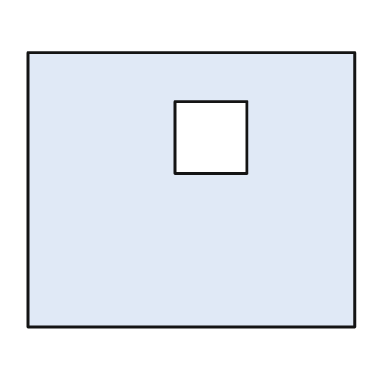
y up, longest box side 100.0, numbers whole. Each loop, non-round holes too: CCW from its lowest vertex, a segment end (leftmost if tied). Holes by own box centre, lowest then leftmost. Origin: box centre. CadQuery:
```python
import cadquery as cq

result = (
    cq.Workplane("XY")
    .moveTo(-50.0, -42.0)
    .lineTo(50.0, -42.0)
    .lineTo(50.0, 42.0)
    .lineTo(-50.0, 42.0)
    .close()
    .moveTo(-5.0, 5.0)
    .lineTo(17.0, 5.0)
    .lineTo(17.0, 27.0)
    .lineTo(-5.0, 27.0)
    .close()
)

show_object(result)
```